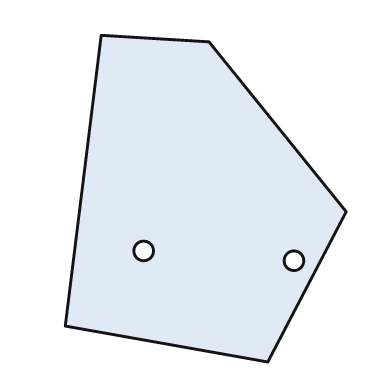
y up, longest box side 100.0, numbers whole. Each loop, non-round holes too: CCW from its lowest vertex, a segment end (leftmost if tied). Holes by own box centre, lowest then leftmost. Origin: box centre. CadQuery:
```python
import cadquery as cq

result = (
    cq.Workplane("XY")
    .moveTo(19.0, -50.0)
    .lineTo(43.0, -4.0)
    .lineTo(1.0, 48.0)
    .lineTo(-32.0, 50.0)
    .lineTo(-43.0, -39.0)
    .close()
    .moveTo(27.0, -19.0)
    .circle(3.0)
    .moveTo(-19.0, -16.0)
    .circle(3.0)
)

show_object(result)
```